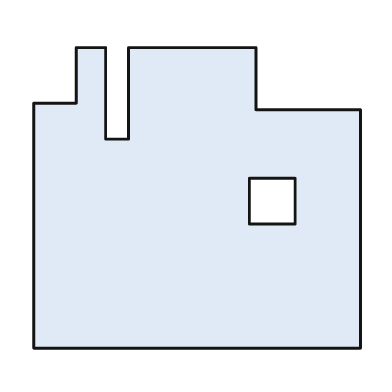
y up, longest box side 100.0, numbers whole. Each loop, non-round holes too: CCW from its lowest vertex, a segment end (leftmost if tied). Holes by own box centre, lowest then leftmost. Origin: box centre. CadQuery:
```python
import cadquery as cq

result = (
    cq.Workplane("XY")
    .moveTo(-50.0, -46.0)
    .lineTo(50.0, -46.0)
    .lineTo(50.0, 27.0)
    .lineTo(18.0, 27.0)
    .lineTo(18.0, 46.0)
    .lineTo(-21.0, 46.0)
    .lineTo(-21.0, 18.0)
    .lineTo(-28.0, 18.0)
    .lineTo(-28.0, 46.0)
    .lineTo(-37.0, 46.0)
    .lineTo(-37.0, 29.0)
    .lineTo(-50.0, 29.0)
    .close()
    .moveTo(16.0, -8.0)
    .lineTo(30.0, -8.0)
    .lineTo(30.0, 6.0)
    .lineTo(16.0, 6.0)
    .close()
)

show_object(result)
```